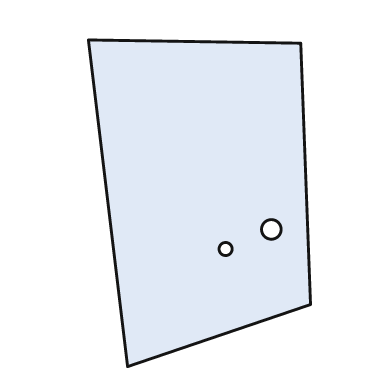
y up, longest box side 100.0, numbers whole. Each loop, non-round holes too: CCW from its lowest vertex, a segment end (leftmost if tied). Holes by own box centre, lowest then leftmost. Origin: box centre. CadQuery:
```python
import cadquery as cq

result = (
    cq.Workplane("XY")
    .moveTo(-22.0, -50.0)
    .lineTo(34.0, -31.0)
    .lineTo(31.0, 49.0)
    .lineTo(-34.0, 50.0)
    .close()
    .moveTo(8.0, -14.0)
    .circle(2.0)
    .moveTo(22.0, -8.0)
    .circle(3.0)
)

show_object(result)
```